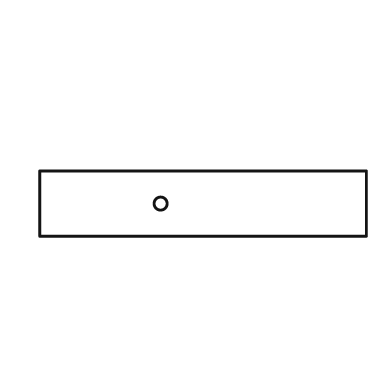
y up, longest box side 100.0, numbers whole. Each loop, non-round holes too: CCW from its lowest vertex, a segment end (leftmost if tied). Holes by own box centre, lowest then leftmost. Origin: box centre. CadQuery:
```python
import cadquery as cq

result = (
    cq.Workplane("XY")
    .moveTo(-50.0, -10.0)
    .lineTo(50.0, -10.0)
    .lineTo(50.0, 10.0)
    .lineTo(-50.0, 10.0)
    .close()
    .moveTo(-13.0, 0.0)
    .circle(2.0)
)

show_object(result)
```